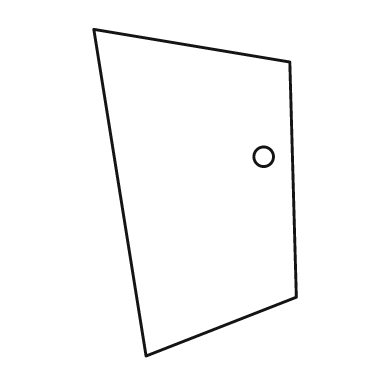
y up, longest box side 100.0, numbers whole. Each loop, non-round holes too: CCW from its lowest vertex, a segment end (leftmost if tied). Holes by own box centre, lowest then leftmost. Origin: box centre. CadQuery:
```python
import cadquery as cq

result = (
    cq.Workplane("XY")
    .moveTo(-15.0, -50.0)
    .lineTo(31.0, -32.0)
    .lineTo(29.0, 40.0)
    .lineTo(-31.0, 50.0)
    .close()
    .moveTo(21.0, 11.0)
    .circle(3.0)
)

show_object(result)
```